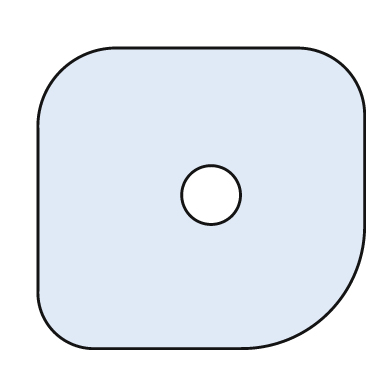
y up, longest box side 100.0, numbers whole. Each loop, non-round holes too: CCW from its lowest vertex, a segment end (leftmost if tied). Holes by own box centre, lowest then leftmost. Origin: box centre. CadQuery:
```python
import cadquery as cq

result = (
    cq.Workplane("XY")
    .moveTo(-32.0, -46.0)
    .lineTo(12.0, -46.0)
    .threePointArc((39.0, -35.0), (50.0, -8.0))
    .lineTo(50.0, 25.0)
    .threePointArc((44.0, 40.0), (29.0, 46.0))
    .lineTo(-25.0, 46.0)
    .threePointArc((-43.0, 39.0), (-50.0, 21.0))
    .lineTo(-50.0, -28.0)
    .threePointArc((-45.0, -41.0), (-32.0, -46.0))
    .close()
    .moveTo(3.0, 1.0)
    .circle(9.0)
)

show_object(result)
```